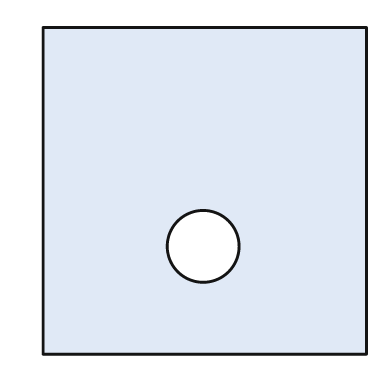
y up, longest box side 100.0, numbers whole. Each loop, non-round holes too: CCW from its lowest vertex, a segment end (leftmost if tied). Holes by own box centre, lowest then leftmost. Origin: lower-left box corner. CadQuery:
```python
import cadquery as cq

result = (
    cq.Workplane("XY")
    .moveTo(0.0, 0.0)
    .lineTo(99.0, 0.0)
    .lineTo(99.0, 100.0)
    .lineTo(0.0, 100.0)
    .close()
    .moveTo(49.0, 33.0)
    .circle(11.0)
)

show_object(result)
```